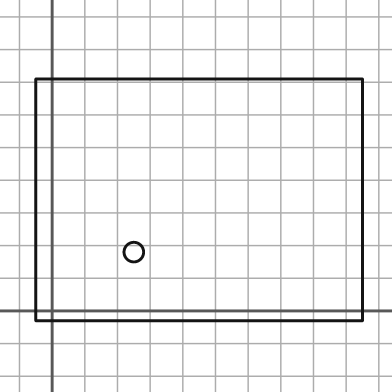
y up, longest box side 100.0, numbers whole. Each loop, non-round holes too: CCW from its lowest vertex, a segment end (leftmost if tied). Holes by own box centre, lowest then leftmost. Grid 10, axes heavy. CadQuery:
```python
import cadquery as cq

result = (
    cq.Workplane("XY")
    .moveTo(-5.0, -3.0)
    .lineTo(95.0, -3.0)
    .lineTo(95.0, 71.0)
    .lineTo(-5.0, 71.0)
    .close()
    .moveTo(25.0, 18.0)
    .circle(3.0)
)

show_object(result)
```